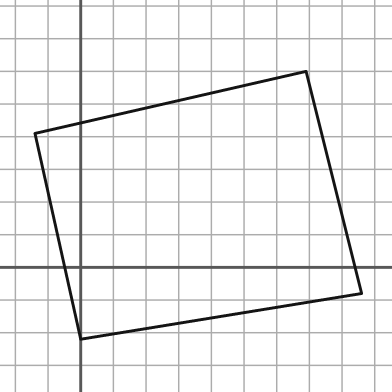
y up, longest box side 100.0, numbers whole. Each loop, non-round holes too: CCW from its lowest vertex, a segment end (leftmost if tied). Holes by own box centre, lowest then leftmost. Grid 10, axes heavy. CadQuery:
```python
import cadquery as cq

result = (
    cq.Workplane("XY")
    .moveTo(0.0, -22.0)
    .lineTo(86.0, -8.0)
    .lineTo(69.0, 60.0)
    .lineTo(-14.0, 41.0)
    .close()
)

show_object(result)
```